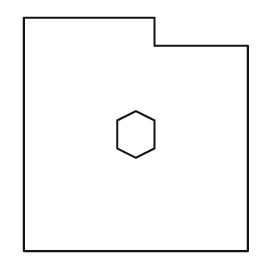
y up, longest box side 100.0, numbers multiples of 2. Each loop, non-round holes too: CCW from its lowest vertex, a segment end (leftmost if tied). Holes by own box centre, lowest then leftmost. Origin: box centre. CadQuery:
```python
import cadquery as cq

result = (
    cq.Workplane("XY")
    .moveTo(-48.0, -50.0)
    .lineTo(48.0, -50.0)
    .lineTo(48.0, 38.0)
    .lineTo(8.0, 38.0)
    .lineTo(8.0, 50.0)
    .lineTo(-48.0, 50.0)
    .close()
    .moveTo(0.0, -10.0)
    .lineTo(8.0, -6.0)
    .lineTo(8.0, 6.0)
    .lineTo(0.0, 10.0)
    .lineTo(-8.0, 6.0)
    .lineTo(-8.0, -6.0)
    .close()
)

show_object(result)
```